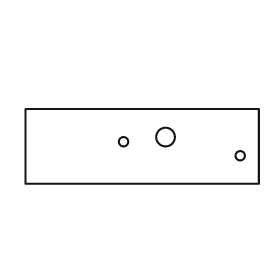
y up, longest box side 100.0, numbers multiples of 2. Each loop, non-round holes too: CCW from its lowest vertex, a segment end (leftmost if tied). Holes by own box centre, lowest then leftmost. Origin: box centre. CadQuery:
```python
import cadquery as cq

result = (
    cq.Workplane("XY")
    .moveTo(-50.0, -16.0)
    .lineTo(50.0, -16.0)
    .lineTo(50.0, 16.0)
    .lineTo(-50.0, 16.0)
    .close()
    .moveTo(42.0, -4.0)
    .circle(2.0)
    .moveTo(-8.0, 2.0)
    .circle(2.0)
    .moveTo(10.0, 4.0)
    .circle(4.0)
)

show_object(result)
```